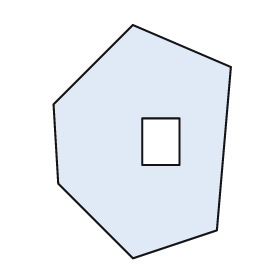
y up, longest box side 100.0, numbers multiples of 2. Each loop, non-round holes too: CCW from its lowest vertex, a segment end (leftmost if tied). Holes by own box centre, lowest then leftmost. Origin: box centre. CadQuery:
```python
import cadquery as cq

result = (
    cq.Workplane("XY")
    .moveTo(-4.0, -50.0)
    .lineTo(32.0, -38.0)
    .lineTo(38.0, 32.0)
    .lineTo(-4.0, 50.0)
    .lineTo(-38.0, 16.0)
    .lineTo(-36.0, -18.0)
    .close()
    .moveTo(0.0, -10.0)
    .lineTo(16.0, -10.0)
    .lineTo(16.0, 10.0)
    .lineTo(0.0, 10.0)
    .close()
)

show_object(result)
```